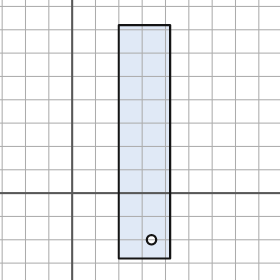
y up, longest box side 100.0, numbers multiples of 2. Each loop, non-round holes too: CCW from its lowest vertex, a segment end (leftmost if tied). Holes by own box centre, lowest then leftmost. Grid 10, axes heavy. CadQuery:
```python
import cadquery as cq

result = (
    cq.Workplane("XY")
    .moveTo(20.0, -28.0)
    .lineTo(42.0, -28.0)
    .lineTo(42.0, 72.0)
    .lineTo(20.0, 72.0)
    .close()
    .moveTo(34.0, -20.0)
    .circle(2.0)
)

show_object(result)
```